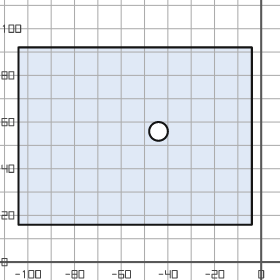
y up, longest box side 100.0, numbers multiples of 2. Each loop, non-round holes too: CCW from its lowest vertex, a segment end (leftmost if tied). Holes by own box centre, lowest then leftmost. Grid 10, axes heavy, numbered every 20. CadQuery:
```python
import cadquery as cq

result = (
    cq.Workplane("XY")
    .moveTo(-104.0, 16.0)
    .lineTo(-4.0, 16.0)
    .lineTo(-4.0, 92.0)
    .lineTo(-104.0, 92.0)
    .close()
    .moveTo(-44.0, 56.0)
    .circle(4.0)
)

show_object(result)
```